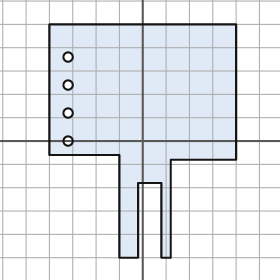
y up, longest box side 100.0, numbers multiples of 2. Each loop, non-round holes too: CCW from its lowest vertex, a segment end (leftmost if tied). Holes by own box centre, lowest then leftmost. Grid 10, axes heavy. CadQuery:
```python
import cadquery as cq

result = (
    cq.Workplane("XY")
    .moveTo(-10.0, -50.0)
    .lineTo(-2.0, -50.0)
    .lineTo(-2.0, -18.0)
    .lineTo(8.0, -18.0)
    .lineTo(8.0, -50.0)
    .lineTo(12.0, -50.0)
    .lineTo(12.0, -8.0)
    .lineTo(40.0, -8.0)
    .lineTo(40.0, 50.0)
    .lineTo(-40.0, 50.0)
    .lineTo(-40.0, -6.0)
    .lineTo(-10.0, -6.0)
    .close()
    .moveTo(-32.0, 0.0)
    .circle(2.0)
    .moveTo(-32.0, 12.0)
    .circle(2.0)
    .moveTo(-32.0, 24.0)
    .circle(2.0)
    .moveTo(-32.0, 36.0)
    .circle(2.0)
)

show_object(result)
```